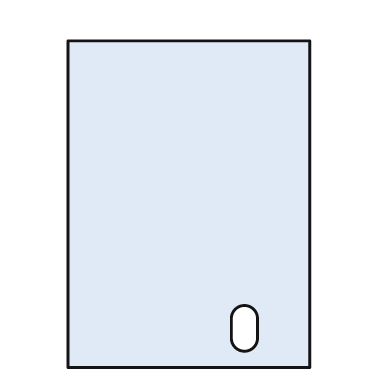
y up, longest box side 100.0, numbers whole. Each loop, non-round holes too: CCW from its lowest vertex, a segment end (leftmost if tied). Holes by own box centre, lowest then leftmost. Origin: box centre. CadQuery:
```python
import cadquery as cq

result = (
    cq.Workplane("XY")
    .moveTo(-37.0, -50.0)
    .lineTo(37.0, -50.0)
    .lineTo(37.0, 50.0)
    .lineTo(-37.0, 50.0)
    .close()
    .moveTo(13.0, -41.0)
    .threePointArc((17.0, -45.0), (21.0, -41.0))
    .lineTo(21.0, -35.0)
    .threePointArc((17.0, -31.0), (13.0, -35.0))
    .close()
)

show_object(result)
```